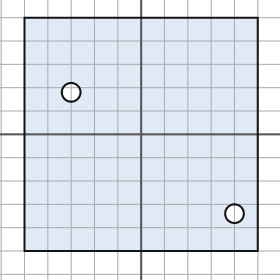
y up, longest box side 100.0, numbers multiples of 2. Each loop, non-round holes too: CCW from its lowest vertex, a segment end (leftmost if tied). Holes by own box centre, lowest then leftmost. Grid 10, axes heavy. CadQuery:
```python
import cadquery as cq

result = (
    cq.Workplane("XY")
    .moveTo(-50.0, -50.0)
    .lineTo(50.0, -50.0)
    .lineTo(50.0, 50.0)
    .lineTo(-50.0, 50.0)
    .close()
    .moveTo(40.0, -34.0)
    .circle(4.0)
    .moveTo(-30.0, 18.0)
    .circle(4.0)
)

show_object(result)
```